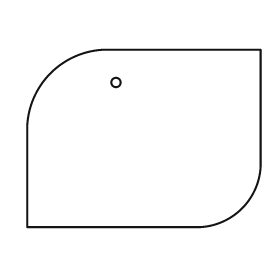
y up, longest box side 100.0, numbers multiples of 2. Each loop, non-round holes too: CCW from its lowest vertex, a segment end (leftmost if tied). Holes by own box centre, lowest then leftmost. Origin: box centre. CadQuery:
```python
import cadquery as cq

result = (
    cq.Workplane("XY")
    .moveTo(-50.0, -38.0)
    .lineTo(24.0, -38.0)
    .threePointArc((42.0, -30.0), (50.0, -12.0))
    .lineTo(50.0, 38.0)
    .lineTo(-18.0, 38.0)
    .threePointArc((-40.0, 28.0), (-50.0, 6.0))
    .close()
    .moveTo(-12.0, 24.0)
    .circle(2.0)
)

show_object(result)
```